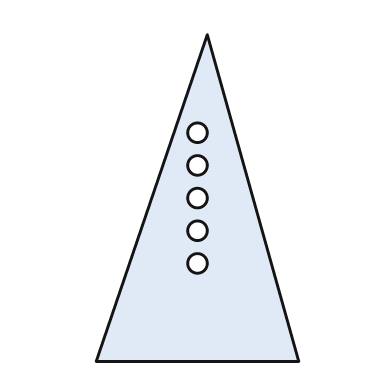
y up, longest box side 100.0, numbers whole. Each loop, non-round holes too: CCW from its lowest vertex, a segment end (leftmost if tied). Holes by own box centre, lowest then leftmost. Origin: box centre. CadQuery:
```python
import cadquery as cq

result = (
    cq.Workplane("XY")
    .moveTo(-31.0, -50.0)
    .lineTo(31.0, -50.0)
    .lineTo(3.0, 50.0)
    .close()
    .moveTo(0.0, -20.0)
    .circle(3.0)
    .moveTo(0.0, -10.0)
    .circle(3.0)
    .moveTo(0.0, 0.0)
    .circle(3.0)
    .moveTo(0.0, 10.0)
    .circle(3.0)
    .moveTo(0.0, 20.0)
    .circle(3.0)
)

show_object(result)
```